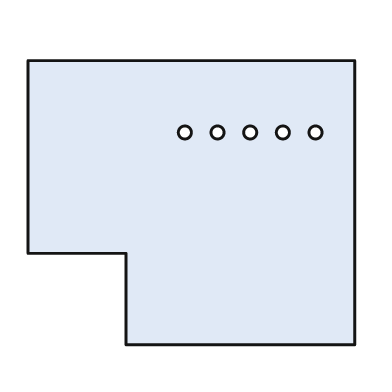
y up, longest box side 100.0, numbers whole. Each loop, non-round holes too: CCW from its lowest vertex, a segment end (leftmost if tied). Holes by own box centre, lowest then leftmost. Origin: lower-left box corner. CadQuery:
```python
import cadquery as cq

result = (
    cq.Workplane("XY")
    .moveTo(30.0, 0.0)
    .lineTo(100.0, 0.0)
    .lineTo(100.0, 87.0)
    .lineTo(0.0, 87.0)
    .lineTo(0.0, 28.0)
    .lineTo(30.0, 28.0)
    .close()
    .moveTo(48.0, 65.0)
    .circle(2.0)
    .moveTo(58.0, 65.0)
    .circle(2.0)
    .moveTo(68.0, 65.0)
    .circle(2.0)
    .moveTo(78.0, 65.0)
    .circle(2.0)
    .moveTo(88.0, 65.0)
    .circle(2.0)
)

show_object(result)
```